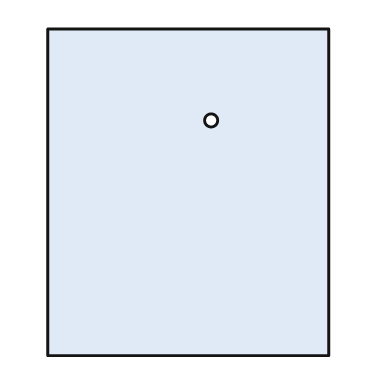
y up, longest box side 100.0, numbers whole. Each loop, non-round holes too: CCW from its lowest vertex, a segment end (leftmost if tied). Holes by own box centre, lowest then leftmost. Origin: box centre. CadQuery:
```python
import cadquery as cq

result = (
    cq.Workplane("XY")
    .moveTo(-43.0, -50.0)
    .lineTo(43.0, -50.0)
    .lineTo(43.0, 50.0)
    .lineTo(-43.0, 50.0)
    .close()
    .moveTo(7.0, 22.0)
    .circle(2.0)
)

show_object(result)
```